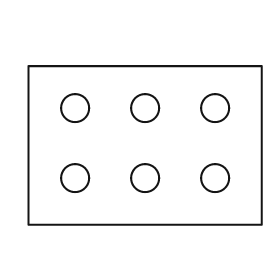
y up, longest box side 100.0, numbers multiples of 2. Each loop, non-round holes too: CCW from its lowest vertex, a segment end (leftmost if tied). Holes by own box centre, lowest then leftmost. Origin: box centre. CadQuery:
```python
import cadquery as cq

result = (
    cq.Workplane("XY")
    .moveTo(-50.0, -34.0)
    .lineTo(50.0, -34.0)
    .lineTo(50.0, 34.0)
    .lineTo(-50.0, 34.0)
    .close()
    .moveTo(-30.0, -14.0)
    .circle(6.0)
    .moveTo(0.0, -14.0)
    .circle(6.0)
    .moveTo(30.0, -14.0)
    .circle(6.0)
    .moveTo(-30.0, 16.0)
    .circle(6.0)
    .moveTo(0.0, 16.0)
    .circle(6.0)
    .moveTo(30.0, 16.0)
    .circle(6.0)
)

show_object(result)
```